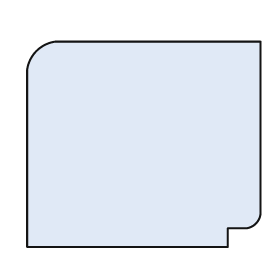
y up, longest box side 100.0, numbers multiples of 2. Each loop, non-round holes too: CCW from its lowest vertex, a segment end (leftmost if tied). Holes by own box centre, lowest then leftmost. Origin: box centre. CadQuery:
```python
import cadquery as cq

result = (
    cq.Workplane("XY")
    .moveTo(-50.0, -44.0)
    .lineTo(36.0, -44.0)
    .lineTo(36.0, -36.0)
    .lineTo(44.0, -36.0)
    .threePointArc((48.0, -34.0), (50.0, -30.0))
    .lineTo(50.0, 44.0)
    .lineTo(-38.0, 44.0)
    .threePointArc((-46.0, 40.0), (-50.0, 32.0))
    .close()
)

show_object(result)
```